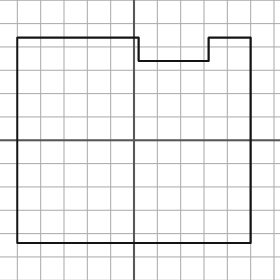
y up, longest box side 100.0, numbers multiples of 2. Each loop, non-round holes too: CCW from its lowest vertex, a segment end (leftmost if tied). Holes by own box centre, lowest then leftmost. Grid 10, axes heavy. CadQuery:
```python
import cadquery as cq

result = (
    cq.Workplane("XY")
    .moveTo(-50.0, -44.0)
    .lineTo(50.0, -44.0)
    .lineTo(50.0, 44.0)
    .lineTo(32.0, 44.0)
    .lineTo(32.0, 34.0)
    .lineTo(2.0, 34.0)
    .lineTo(2.0, 44.0)
    .lineTo(-50.0, 44.0)
    .close()
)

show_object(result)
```